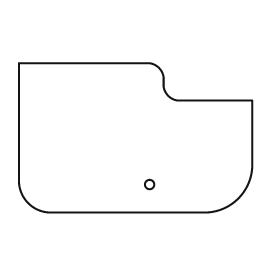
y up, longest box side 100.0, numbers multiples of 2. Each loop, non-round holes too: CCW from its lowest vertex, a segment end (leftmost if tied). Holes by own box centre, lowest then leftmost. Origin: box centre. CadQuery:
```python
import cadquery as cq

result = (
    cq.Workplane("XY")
    .moveTo(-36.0, -32.0)
    .lineTo(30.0, -32.0)
    .threePointArc((44.0, -26.0), (50.0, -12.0))
    .lineTo(50.0, 16.0)
    .lineTo(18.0, 16.0)
    .threePointArc((14.0, 18.0), (12.0, 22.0))
    .lineTo(12.0, 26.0)
    .threePointArc((10.0, 30.0), (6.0, 32.0))
    .lineTo(-50.0, 32.0)
    .lineTo(-50.0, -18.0)
    .threePointArc((-46.0, -28.0), (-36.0, -32.0))
    .close()
    .moveTo(6.0, -20.0)
    .circle(2.0)
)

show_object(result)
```